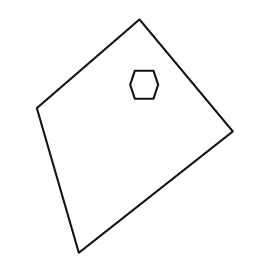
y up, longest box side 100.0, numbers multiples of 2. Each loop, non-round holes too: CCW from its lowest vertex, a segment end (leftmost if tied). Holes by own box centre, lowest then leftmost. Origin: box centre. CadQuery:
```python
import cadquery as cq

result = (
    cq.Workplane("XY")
    .moveTo(-24.0, -50.0)
    .lineTo(42.0, 2.0)
    .lineTo(2.0, 50.0)
    .lineTo(-42.0, 12.0)
    .close()
    .moveTo(0.0, 16.0)
    .lineTo(8.0, 16.0)
    .lineTo(10.0, 22.0)
    .lineTo(8.0, 28.0)
    .lineTo(0.0, 28.0)
    .lineTo(-2.0, 22.0)
    .close()
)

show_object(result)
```